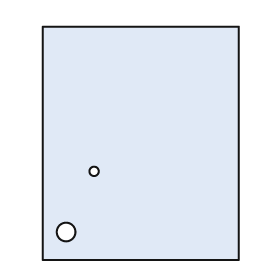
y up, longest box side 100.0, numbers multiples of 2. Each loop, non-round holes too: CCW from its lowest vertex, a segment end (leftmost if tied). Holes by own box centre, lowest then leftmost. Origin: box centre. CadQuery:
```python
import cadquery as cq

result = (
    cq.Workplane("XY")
    .moveTo(-42.0, -50.0)
    .lineTo(42.0, -50.0)
    .lineTo(42.0, 50.0)
    .lineTo(-42.0, 50.0)
    .close()
    .moveTo(-32.0, -38.0)
    .circle(4.0)
    .moveTo(-20.0, -12.0)
    .circle(2.0)
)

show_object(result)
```